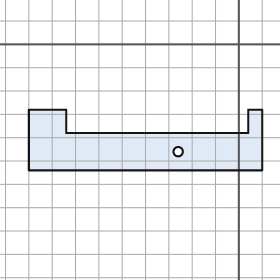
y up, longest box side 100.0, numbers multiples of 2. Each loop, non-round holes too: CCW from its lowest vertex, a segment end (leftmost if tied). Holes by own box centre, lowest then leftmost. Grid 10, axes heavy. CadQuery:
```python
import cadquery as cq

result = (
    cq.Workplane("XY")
    .moveTo(-90.0, -54.0)
    .lineTo(10.0, -54.0)
    .lineTo(10.0, -28.0)
    .lineTo(4.0, -28.0)
    .lineTo(4.0, -38.0)
    .lineTo(-74.0, -38.0)
    .lineTo(-74.0, -28.0)
    .lineTo(-90.0, -28.0)
    .close()
    .moveTo(-26.0, -46.0)
    .circle(2.0)
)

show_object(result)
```